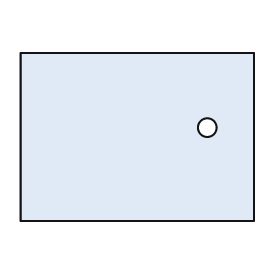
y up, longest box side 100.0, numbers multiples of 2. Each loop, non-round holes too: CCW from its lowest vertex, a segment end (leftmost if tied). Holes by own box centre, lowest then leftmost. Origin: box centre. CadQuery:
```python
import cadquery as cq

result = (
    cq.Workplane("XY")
    .moveTo(-50.0, -36.0)
    .lineTo(50.0, -36.0)
    .lineTo(50.0, 36.0)
    .lineTo(-50.0, 36.0)
    .close()
    .moveTo(30.0, 4.0)
    .circle(4.0)
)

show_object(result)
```